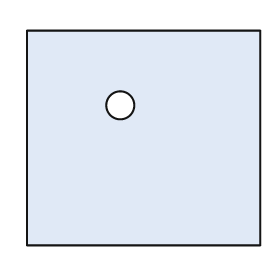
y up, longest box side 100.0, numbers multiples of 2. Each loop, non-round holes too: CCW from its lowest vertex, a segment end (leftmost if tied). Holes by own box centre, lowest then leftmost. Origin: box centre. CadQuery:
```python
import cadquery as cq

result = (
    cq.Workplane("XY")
    .moveTo(-50.0, -46.0)
    .lineTo(50.0, -46.0)
    .lineTo(50.0, 46.0)
    .lineTo(-50.0, 46.0)
    .close()
    .moveTo(-10.0, 14.0)
    .circle(6.0)
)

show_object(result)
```